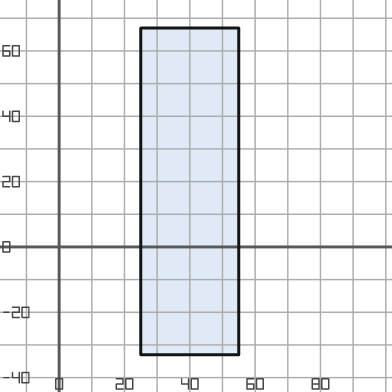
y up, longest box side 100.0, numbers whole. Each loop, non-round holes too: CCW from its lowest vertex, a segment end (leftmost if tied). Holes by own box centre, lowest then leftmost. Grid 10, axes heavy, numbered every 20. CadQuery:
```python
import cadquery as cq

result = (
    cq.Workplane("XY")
    .moveTo(25.0, -33.0)
    .lineTo(55.0, -33.0)
    .lineTo(55.0, 67.0)
    .lineTo(25.0, 67.0)
    .close()
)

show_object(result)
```